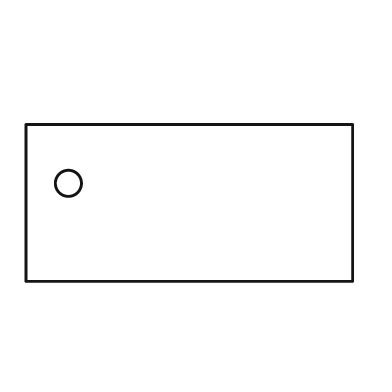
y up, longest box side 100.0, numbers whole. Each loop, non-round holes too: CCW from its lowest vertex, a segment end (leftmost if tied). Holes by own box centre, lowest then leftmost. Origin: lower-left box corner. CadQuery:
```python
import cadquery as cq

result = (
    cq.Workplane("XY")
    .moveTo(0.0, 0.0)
    .lineTo(100.0, 0.0)
    .lineTo(100.0, 48.0)
    .lineTo(0.0, 48.0)
    .close()
    .moveTo(13.0, 30.0)
    .circle(4.0)
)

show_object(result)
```